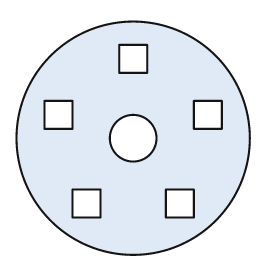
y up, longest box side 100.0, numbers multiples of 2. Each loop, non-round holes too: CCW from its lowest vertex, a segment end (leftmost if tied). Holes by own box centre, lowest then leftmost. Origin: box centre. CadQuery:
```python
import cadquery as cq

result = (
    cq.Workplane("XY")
    .moveTo(0.0, 0.0)
    .circle(50.0)
    .moveTo(-26.0, -34.0)
    .lineTo(-14.0, -34.0)
    .lineTo(-14.0, -22.0)
    .lineTo(-26.0, -22.0)
    .close()
    .moveTo(14.0, -34.0)
    .lineTo(26.0, -34.0)
    .lineTo(26.0, -22.0)
    .lineTo(14.0, -22.0)
    .close()
    .moveTo(0.0, 0.0)
    .circle(10.0)
    .moveTo(-38.0, 4.0)
    .lineTo(-26.0, 4.0)
    .lineTo(-26.0, 16.0)
    .lineTo(-38.0, 16.0)
    .close()
    .moveTo(26.0, 4.0)
    .lineTo(38.0, 4.0)
    .lineTo(38.0, 16.0)
    .lineTo(26.0, 16.0)
    .close()
    .moveTo(-6.0, 28.0)
    .lineTo(6.0, 28.0)
    .lineTo(6.0, 40.0)
    .lineTo(-6.0, 40.0)
    .close()
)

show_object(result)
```